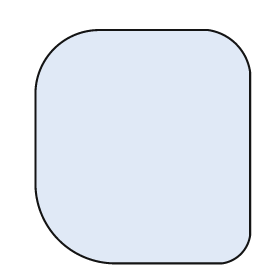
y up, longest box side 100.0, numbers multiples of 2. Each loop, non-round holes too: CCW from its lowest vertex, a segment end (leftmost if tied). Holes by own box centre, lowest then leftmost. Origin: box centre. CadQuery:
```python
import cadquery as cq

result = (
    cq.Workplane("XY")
    .moveTo(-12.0, -50.0)
    .lineTo(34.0, -50.0)
    .threePointArc((42.0, -46.0), (46.0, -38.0))
    .lineTo(46.0, 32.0)
    .threePointArc((40.0, 44.0), (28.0, 50.0))
    .lineTo(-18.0, 50.0)
    .threePointArc((-38.0, 42.0), (-46.0, 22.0))
    .lineTo(-46.0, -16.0)
    .threePointArc((-36.0, -40.0), (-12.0, -50.0))
    .close()
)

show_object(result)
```